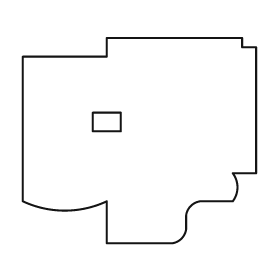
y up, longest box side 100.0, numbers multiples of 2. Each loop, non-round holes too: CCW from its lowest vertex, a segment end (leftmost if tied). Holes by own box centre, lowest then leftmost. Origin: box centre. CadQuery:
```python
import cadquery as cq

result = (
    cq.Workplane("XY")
    .moveTo(-14.0, -44.0)
    .lineTo(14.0, -44.0)
    .threePointArc((18.0, -42.0), (20.0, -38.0))
    .lineTo(20.0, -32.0)
    .threePointArc((22.0, -28.0), (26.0, -26.0))
    .lineTo(40.0, -26.0)
    .threePointArc((42.0, -20.0), (40.0, -14.0))
    .lineTo(50.0, -14.0)
    .lineTo(50.0, 40.0)
    .lineTo(44.0, 40.0)
    .lineTo(44.0, 44.0)
    .lineTo(-14.0, 44.0)
    .lineTo(-14.0, 36.0)
    .lineTo(-50.0, 36.0)
    .lineTo(-50.0, -26.0)
    .threePointArc((-32.0, -30.0), (-14.0, -26.0))
    .close()
    .moveTo(-20.0, 4.0)
    .lineTo(-8.0, 4.0)
    .lineTo(-8.0, 12.0)
    .lineTo(-20.0, 12.0)
    .close()
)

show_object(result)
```